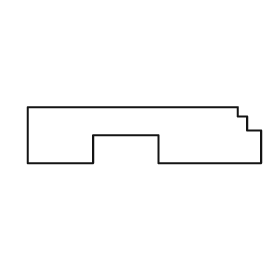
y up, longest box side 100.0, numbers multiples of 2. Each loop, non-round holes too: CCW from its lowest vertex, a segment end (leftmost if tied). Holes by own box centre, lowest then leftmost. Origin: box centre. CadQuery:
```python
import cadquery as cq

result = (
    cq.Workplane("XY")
    .moveTo(-50.0, -12.0)
    .lineTo(-22.0, -12.0)
    .lineTo(-22.0, 0.0)
    .lineTo(6.0, 0.0)
    .lineTo(6.0, -12.0)
    .lineTo(50.0, -12.0)
    .lineTo(50.0, 2.0)
    .lineTo(44.0, 2.0)
    .lineTo(44.0, 8.0)
    .lineTo(40.0, 8.0)
    .lineTo(40.0, 12.0)
    .lineTo(-50.0, 12.0)
    .close()
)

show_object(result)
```